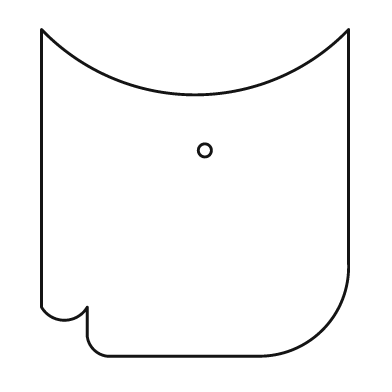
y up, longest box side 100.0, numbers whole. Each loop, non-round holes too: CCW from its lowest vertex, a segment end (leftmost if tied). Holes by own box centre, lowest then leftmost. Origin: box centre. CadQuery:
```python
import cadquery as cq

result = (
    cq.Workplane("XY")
    .moveTo(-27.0, -50.0)
    .lineTo(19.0, -50.0)
    .threePointArc((39.0, -42.0), (47.0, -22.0))
    .lineTo(47.0, 50.0)
    .threePointArc((0.0, 30.0), (-47.0, 50.0))
    .lineTo(-47.0, -35.0)
    .threePointArc((-40.0, -39.0), (-33.0, -35.0))
    .lineTo(-33.0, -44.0)
    .threePointArc((-31.0, -48.0), (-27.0, -50.0))
    .close()
    .moveTo(3.0, 13.0)
    .circle(2.0)
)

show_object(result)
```